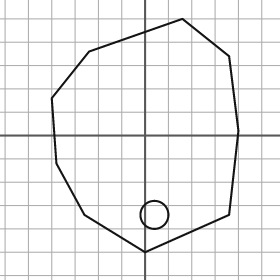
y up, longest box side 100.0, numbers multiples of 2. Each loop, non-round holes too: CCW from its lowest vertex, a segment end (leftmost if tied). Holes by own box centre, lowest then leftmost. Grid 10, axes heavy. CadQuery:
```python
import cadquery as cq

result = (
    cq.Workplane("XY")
    .moveTo(0.0, -50.0)
    .lineTo(36.0, -34.0)
    .lineTo(40.0, 2.0)
    .lineTo(36.0, 34.0)
    .lineTo(16.0, 50.0)
    .lineTo(-24.0, 36.0)
    .lineTo(-40.0, 16.0)
    .lineTo(-38.0, -12.0)
    .lineTo(-26.0, -34.0)
    .close()
    .moveTo(4.0, -34.0)
    .circle(6.0)
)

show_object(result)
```